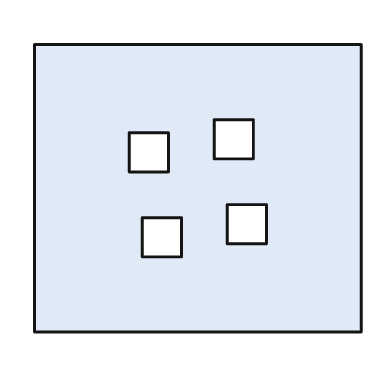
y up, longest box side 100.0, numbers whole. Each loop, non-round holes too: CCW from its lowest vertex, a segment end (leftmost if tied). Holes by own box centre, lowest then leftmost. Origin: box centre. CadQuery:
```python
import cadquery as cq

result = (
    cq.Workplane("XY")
    .moveTo(-50.0, -44.0)
    .lineTo(50.0, -44.0)
    .lineTo(50.0, 44.0)
    .lineTo(-50.0, 44.0)
    .close()
    .moveTo(-17.0, -21.0)
    .lineTo(-5.0, -21.0)
    .lineTo(-5.0, -9.0)
    .lineTo(-17.0, -9.0)
    .close()
    .moveTo(9.0, -17.0)
    .lineTo(21.0, -17.0)
    .lineTo(21.0, -5.0)
    .lineTo(9.0, -5.0)
    .close()
    .moveTo(-21.0, 5.0)
    .lineTo(-9.0, 5.0)
    .lineTo(-9.0, 17.0)
    .lineTo(-21.0, 17.0)
    .close()
    .moveTo(5.0, 9.0)
    .lineTo(17.0, 9.0)
    .lineTo(17.0, 21.0)
    .lineTo(5.0, 21.0)
    .close()
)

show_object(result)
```